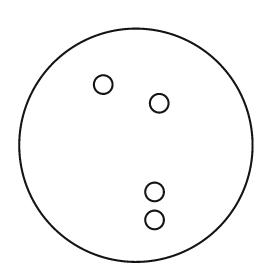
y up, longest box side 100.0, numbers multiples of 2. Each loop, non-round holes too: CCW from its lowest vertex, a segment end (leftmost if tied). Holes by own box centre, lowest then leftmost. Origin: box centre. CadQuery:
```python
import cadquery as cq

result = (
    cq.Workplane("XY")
    .moveTo(0.0, 0.0)
    .circle(50.0)
    .moveTo(8.0, -32.0)
    .circle(4.0)
    .moveTo(8.0, -20.0)
    .circle(4.0)
    .moveTo(10.0, 18.0)
    .circle(4.0)
    .moveTo(-14.0, 26.0)
    .circle(4.0)
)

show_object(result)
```